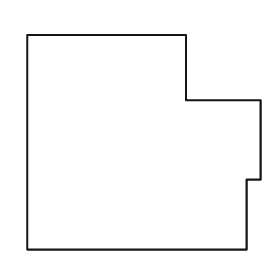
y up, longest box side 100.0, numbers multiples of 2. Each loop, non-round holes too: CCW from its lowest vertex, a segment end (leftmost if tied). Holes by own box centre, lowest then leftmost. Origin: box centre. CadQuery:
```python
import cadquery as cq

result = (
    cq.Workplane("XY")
    .moveTo(-50.0, -46.0)
    .lineTo(44.0, -46.0)
    .lineTo(44.0, -16.0)
    .lineTo(50.0, -16.0)
    .lineTo(50.0, 18.0)
    .lineTo(18.0, 18.0)
    .lineTo(18.0, 46.0)
    .lineTo(-50.0, 46.0)
    .close()
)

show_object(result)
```